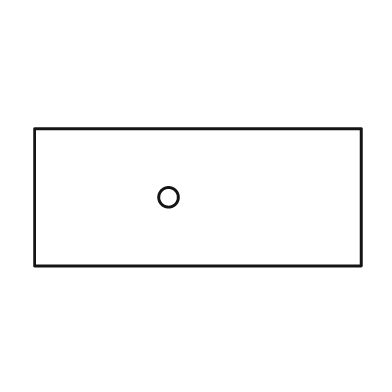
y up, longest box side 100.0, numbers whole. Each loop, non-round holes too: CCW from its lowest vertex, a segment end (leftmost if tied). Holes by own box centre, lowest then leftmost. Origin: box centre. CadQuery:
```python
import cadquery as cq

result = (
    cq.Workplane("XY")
    .moveTo(-50.0, -21.0)
    .lineTo(50.0, -21.0)
    .lineTo(50.0, 21.0)
    .lineTo(-50.0, 21.0)
    .close()
    .moveTo(-9.0, 0.0)
    .circle(3.0)
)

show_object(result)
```